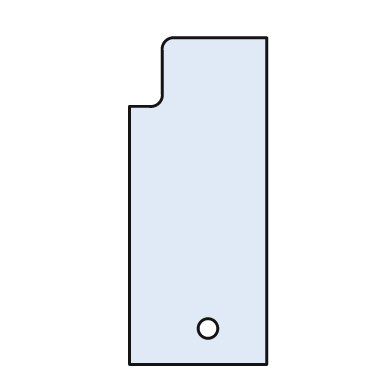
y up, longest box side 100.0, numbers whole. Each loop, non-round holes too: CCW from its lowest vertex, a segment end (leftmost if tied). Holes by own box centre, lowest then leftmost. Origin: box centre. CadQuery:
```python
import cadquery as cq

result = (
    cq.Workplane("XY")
    .moveTo(-21.0, -50.0)
    .lineTo(21.0, -50.0)
    .lineTo(21.0, 50.0)
    .lineTo(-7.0, 50.0)
    .threePointArc((-10.0, 49.0), (-11.0, 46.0))
    .lineTo(-11.0, 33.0)
    .threePointArc((-12.0, 30.0), (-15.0, 29.0))
    .lineTo(-21.0, 29.0)
    .close()
    .moveTo(3.0, -39.0)
    .circle(3.0)
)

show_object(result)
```